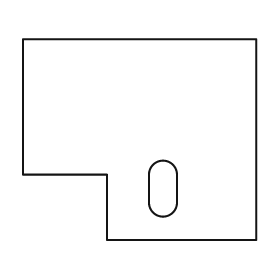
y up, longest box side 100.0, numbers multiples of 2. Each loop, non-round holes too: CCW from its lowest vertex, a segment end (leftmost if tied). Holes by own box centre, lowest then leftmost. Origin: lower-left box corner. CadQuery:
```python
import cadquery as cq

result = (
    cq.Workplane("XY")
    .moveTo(36.0, 0.0)
    .lineTo(100.0, 0.0)
    .lineTo(100.0, 86.0)
    .lineTo(0.0, 86.0)
    .lineTo(0.0, 28.0)
    .lineTo(36.0, 28.0)
    .close()
    .moveTo(54.0, 16.0)
    .threePointArc((60.0, 10.0), (66.0, 16.0))
    .lineTo(66.0, 28.0)
    .threePointArc((60.0, 34.0), (54.0, 28.0))
    .close()
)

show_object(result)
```